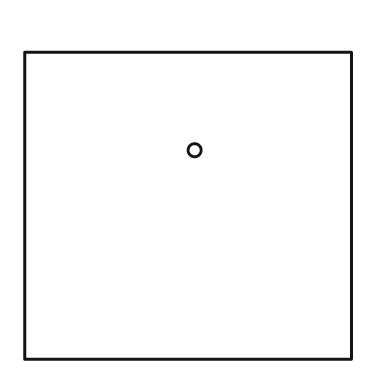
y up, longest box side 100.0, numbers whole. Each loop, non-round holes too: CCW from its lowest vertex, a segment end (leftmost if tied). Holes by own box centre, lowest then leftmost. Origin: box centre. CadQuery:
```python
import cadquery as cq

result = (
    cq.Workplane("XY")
    .moveTo(-50.0, -47.0)
    .lineTo(50.0, -47.0)
    .lineTo(50.0, 47.0)
    .lineTo(-50.0, 47.0)
    .close()
    .moveTo(2.0, 17.0)
    .circle(2.0)
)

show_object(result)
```